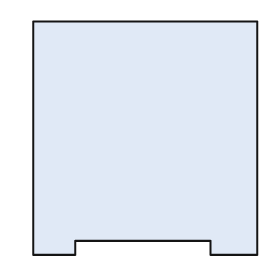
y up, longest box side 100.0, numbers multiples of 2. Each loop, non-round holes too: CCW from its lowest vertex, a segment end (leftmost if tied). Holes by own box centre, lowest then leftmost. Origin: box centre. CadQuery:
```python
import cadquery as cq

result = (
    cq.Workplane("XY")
    .moveTo(-48.0, -50.0)
    .lineTo(-30.0, -50.0)
    .lineTo(-30.0, -44.0)
    .lineTo(28.0, -44.0)
    .lineTo(28.0, -50.0)
    .lineTo(48.0, -50.0)
    .lineTo(48.0, 50.0)
    .lineTo(-48.0, 50.0)
    .close()
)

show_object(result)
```